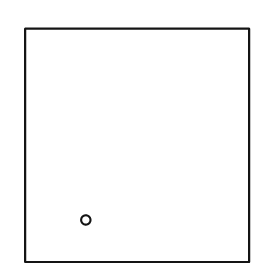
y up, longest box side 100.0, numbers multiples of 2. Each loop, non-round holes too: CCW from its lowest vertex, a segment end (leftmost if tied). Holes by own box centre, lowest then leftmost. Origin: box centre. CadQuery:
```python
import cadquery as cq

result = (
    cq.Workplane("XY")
    .moveTo(-48.0, -50.0)
    .lineTo(48.0, -50.0)
    .lineTo(48.0, 50.0)
    .lineTo(-48.0, 50.0)
    .close()
    .moveTo(-22.0, -32.0)
    .circle(2.0)
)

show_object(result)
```